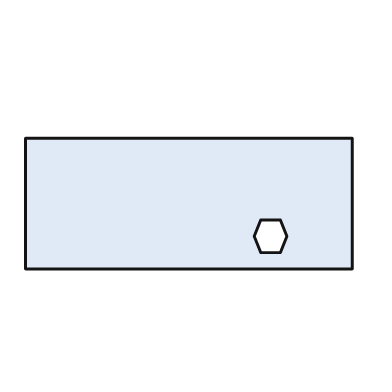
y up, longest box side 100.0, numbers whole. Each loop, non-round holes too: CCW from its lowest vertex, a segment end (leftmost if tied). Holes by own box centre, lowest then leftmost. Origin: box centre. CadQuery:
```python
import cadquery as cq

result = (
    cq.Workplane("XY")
    .moveTo(-50.0, -20.0)
    .lineTo(50.0, -20.0)
    .lineTo(50.0, 20.0)
    .lineTo(-50.0, 20.0)
    .close()
    .moveTo(22.0, -15.0)
    .lineTo(28.0, -15.0)
    .lineTo(30.0, -10.0)
    .lineTo(28.0, -5.0)
    .lineTo(22.0, -5.0)
    .lineTo(20.0, -10.0)
    .close()
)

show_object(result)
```